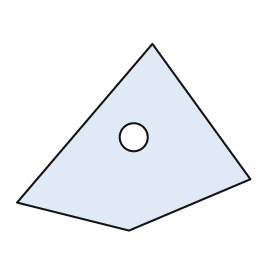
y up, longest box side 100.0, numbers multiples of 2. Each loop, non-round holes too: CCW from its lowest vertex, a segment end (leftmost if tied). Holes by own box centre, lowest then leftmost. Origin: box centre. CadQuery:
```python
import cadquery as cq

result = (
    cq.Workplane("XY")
    .moveTo(-2.0, -40.0)
    .lineTo(50.0, -18.0)
    .lineTo(8.0, 40.0)
    .lineTo(-50.0, -28.0)
    .close()
    .moveTo(0.0, 0.0)
    .circle(6.0)
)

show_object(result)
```